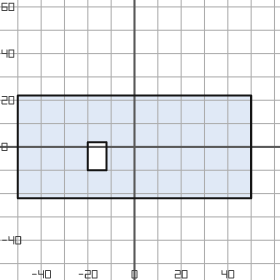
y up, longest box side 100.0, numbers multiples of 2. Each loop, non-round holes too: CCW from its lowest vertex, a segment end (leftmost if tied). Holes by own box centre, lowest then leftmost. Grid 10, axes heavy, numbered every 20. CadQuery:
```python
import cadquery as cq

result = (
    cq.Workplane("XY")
    .moveTo(-50.0, -22.0)
    .lineTo(50.0, -22.0)
    .lineTo(50.0, 22.0)
    .lineTo(-50.0, 22.0)
    .close()
    .moveTo(-20.0, -10.0)
    .lineTo(-12.0, -10.0)
    .lineTo(-12.0, 2.0)
    .lineTo(-20.0, 2.0)
    .close()
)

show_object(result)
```